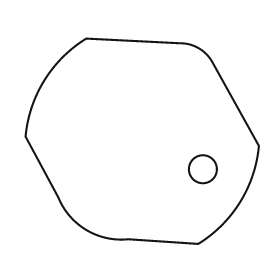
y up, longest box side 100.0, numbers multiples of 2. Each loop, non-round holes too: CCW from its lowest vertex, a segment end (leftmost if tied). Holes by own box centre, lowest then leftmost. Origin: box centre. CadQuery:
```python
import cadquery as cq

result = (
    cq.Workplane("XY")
    .moveTo(24.0, -44.0)
    .threePointArc((42.0, -26.0), (50.0, -2.0))
    .lineTo(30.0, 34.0)
    .threePointArc((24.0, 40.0), (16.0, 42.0))
    .lineTo(-24.0, 44.0)
    .threePointArc((-42.0, 26.0), (-50.0, 2.0))
    .lineTo(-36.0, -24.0)
    .threePointArc((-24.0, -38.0), (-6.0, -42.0))
    .close()
    .moveTo(26.0, -12.0)
    .circle(6.0)
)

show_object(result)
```